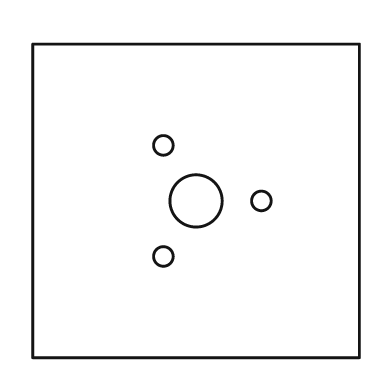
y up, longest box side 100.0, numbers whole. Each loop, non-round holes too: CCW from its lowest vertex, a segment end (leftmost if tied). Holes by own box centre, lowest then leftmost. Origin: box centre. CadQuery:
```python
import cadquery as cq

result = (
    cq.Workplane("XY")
    .moveTo(-50.0, -48.0)
    .lineTo(50.0, -48.0)
    .lineTo(50.0, 48.0)
    .lineTo(-50.0, 48.0)
    .close()
    .moveTo(-10.0, -17.0)
    .circle(3.0)
    .moveTo(0.0, 0.0)
    .circle(8.0)
    .moveTo(20.0, 0.0)
    .circle(3.0)
    .moveTo(-10.0, 17.0)
    .circle(3.0)
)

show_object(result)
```